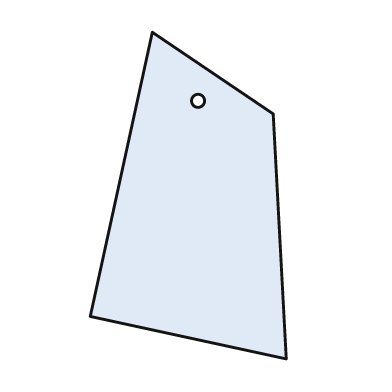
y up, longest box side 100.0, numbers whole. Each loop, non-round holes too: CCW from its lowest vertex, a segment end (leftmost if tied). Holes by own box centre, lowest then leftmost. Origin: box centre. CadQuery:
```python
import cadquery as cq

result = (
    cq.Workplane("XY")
    .moveTo(30.0, -50.0)
    .lineTo(26.0, 25.0)
    .lineTo(-11.0, 50.0)
    .lineTo(-30.0, -37.0)
    .close()
    .moveTo(3.0, 29.0)
    .circle(2.0)
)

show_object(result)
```